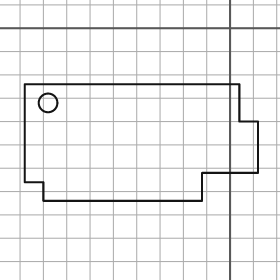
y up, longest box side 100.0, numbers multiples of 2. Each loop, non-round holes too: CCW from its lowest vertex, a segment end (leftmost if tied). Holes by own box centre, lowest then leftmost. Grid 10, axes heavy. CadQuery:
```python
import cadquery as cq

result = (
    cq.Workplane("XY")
    .moveTo(-80.0, -74.0)
    .lineTo(-12.0, -74.0)
    .lineTo(-12.0, -62.0)
    .lineTo(12.0, -62.0)
    .lineTo(12.0, -40.0)
    .lineTo(4.0, -40.0)
    .lineTo(4.0, -24.0)
    .lineTo(-88.0, -24.0)
    .lineTo(-88.0, -66.0)
    .lineTo(-80.0, -66.0)
    .close()
    .moveTo(-78.0, -32.0)
    .circle(4.0)
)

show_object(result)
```